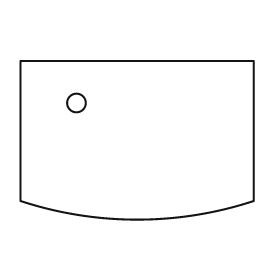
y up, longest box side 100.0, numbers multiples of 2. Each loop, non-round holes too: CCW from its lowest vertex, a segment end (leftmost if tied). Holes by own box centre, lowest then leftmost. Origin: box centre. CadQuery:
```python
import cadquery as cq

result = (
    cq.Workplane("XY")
    .moveTo(-50.0, -26.0)
    .threePointArc((0.0, -34.0), (50.0, -26.0))
    .lineTo(50.0, 34.0)
    .lineTo(-50.0, 34.0)
    .close()
    .moveTo(-26.0, 16.0)
    .circle(4.0)
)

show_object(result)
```